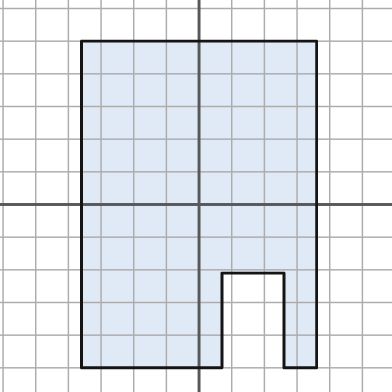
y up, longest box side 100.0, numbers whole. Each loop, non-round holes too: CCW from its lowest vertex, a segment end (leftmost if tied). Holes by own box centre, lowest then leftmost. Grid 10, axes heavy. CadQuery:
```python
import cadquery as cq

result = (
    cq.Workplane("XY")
    .moveTo(-36.0, -50.0)
    .lineTo(7.0, -50.0)
    .lineTo(7.0, -21.0)
    .lineTo(26.0, -21.0)
    .lineTo(26.0, -50.0)
    .lineTo(36.0, -50.0)
    .lineTo(36.0, 50.0)
    .lineTo(-36.0, 50.0)
    .close()
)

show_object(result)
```